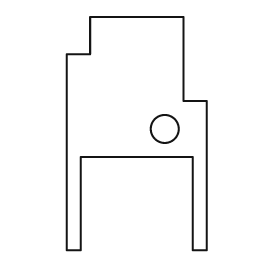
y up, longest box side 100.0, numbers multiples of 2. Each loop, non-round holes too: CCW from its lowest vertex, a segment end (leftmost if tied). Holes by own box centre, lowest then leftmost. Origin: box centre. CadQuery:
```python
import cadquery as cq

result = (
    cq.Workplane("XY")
    .moveTo(-30.0, -50.0)
    .lineTo(-24.0, -50.0)
    .lineTo(-24.0, -10.0)
    .lineTo(24.0, -10.0)
    .lineTo(24.0, -50.0)
    .lineTo(30.0, -50.0)
    .lineTo(30.0, 14.0)
    .lineTo(20.0, 14.0)
    .lineTo(20.0, 50.0)
    .lineTo(-20.0, 50.0)
    .lineTo(-20.0, 34.0)
    .lineTo(-30.0, 34.0)
    .close()
    .moveTo(12.0, 2.0)
    .circle(6.0)
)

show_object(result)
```